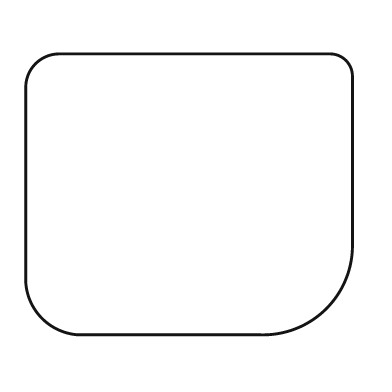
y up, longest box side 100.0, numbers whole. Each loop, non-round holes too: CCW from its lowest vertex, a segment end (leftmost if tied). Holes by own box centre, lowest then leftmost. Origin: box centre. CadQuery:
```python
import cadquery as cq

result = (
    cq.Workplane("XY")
    .moveTo(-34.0, -43.0)
    .lineTo(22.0, -43.0)
    .threePointArc((42.0, -35.0), (50.0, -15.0))
    .lineTo(50.0, 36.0)
    .threePointArc((48.0, 41.0), (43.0, 43.0))
    .lineTo(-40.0, 43.0)
    .threePointArc((-47.0, 40.0), (-50.0, 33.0))
    .lineTo(-50.0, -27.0)
    .threePointArc((-45.0, -38.0), (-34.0, -43.0))
    .close()
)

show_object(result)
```